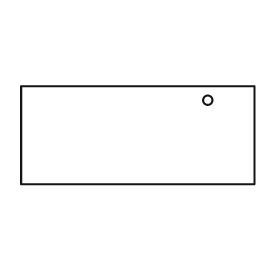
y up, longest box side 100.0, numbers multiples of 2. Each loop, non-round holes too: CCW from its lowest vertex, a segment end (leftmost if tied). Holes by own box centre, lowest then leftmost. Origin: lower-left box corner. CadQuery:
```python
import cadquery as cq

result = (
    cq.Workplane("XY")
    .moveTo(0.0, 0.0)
    .lineTo(100.0, 0.0)
    .lineTo(100.0, 42.0)
    .lineTo(0.0, 42.0)
    .close()
    .moveTo(80.0, 36.0)
    .circle(2.0)
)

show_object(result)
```